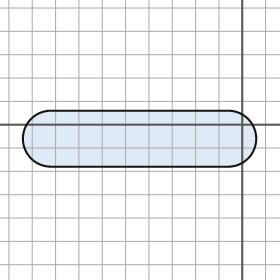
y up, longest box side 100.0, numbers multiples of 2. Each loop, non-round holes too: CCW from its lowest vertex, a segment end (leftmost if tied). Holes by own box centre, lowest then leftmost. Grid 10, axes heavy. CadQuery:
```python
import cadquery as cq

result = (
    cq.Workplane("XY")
    .moveTo(-82.0, -18.0)
    .lineTo(-6.0, -18.0)
    .threePointArc((6.0, -6.0), (-6.0, 6.0))
    .lineTo(-82.0, 6.0)
    .threePointArc((-94.0, -6.0), (-82.0, -18.0))
    .close()
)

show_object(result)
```